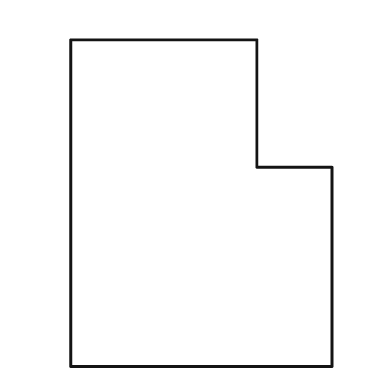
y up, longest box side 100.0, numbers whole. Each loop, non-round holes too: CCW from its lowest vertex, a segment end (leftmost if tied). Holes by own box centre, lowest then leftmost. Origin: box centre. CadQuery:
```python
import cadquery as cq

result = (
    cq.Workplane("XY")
    .moveTo(-40.0, -50.0)
    .lineTo(40.0, -50.0)
    .lineTo(40.0, 11.0)
    .lineTo(17.0, 11.0)
    .lineTo(17.0, 50.0)
    .lineTo(-40.0, 50.0)
    .close()
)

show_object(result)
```